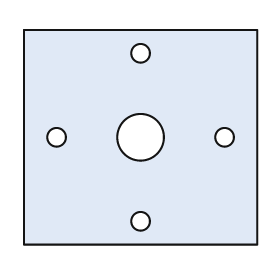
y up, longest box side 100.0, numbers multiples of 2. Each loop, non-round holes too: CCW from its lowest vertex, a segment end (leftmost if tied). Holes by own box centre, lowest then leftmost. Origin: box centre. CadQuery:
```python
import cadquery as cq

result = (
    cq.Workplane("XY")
    .moveTo(-50.0, -46.0)
    .lineTo(50.0, -46.0)
    .lineTo(50.0, 46.0)
    .lineTo(-50.0, 46.0)
    .close()
    .moveTo(0.0, -36.0)
    .circle(4.0)
    .moveTo(-36.0, 0.0)
    .circle(4.0)
    .moveTo(0.0, 0.0)
    .circle(10.0)
    .moveTo(36.0, 0.0)
    .circle(4.0)
    .moveTo(0.0, 36.0)
    .circle(4.0)
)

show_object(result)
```